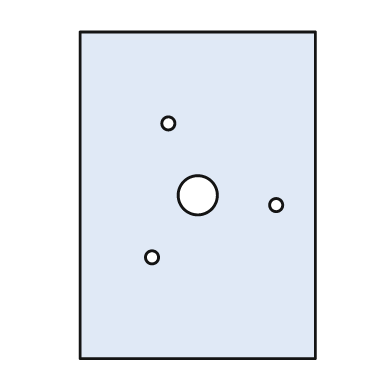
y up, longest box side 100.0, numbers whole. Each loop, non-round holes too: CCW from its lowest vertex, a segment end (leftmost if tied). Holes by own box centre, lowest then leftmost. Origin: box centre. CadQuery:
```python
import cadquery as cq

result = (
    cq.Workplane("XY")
    .moveTo(-36.0, -50.0)
    .lineTo(36.0, -50.0)
    .lineTo(36.0, 50.0)
    .lineTo(-36.0, 50.0)
    .close()
    .moveTo(-14.0, -19.0)
    .circle(2.0)
    .moveTo(24.0, -3.0)
    .circle(2.0)
    .moveTo(0.0, 0.0)
    .circle(6.0)
    .moveTo(-9.0, 22.0)
    .circle(2.0)
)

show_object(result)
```